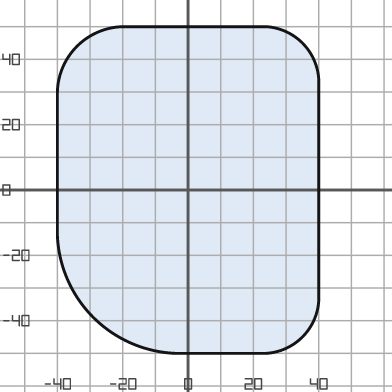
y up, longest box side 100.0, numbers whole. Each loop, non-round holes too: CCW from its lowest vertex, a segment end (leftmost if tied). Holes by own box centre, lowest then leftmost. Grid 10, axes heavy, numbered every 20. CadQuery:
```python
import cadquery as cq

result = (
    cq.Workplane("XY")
    .moveTo(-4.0, -50.0)
    .lineTo(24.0, -50.0)
    .threePointArc((35.0, -45.0), (40.0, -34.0))
    .lineTo(40.0, 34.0)
    .threePointArc((35.0, 45.0), (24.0, 50.0))
    .lineTo(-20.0, 50.0)
    .threePointArc((-34.0, 44.0), (-40.0, 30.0))
    .lineTo(-40.0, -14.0)
    .threePointArc((-29.0, -39.0), (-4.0, -50.0))
    .close()
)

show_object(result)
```